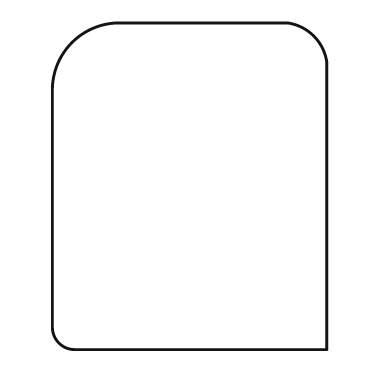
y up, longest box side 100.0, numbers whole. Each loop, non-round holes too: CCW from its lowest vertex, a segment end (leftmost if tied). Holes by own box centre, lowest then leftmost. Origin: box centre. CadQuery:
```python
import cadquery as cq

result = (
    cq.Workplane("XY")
    .moveTo(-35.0, -50.0)
    .lineTo(42.0, -50.0)
    .lineTo(42.0, 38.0)
    .threePointArc((38.0, 46.0), (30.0, 50.0))
    .lineTo(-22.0, 50.0)
    .threePointArc((-36.0, 44.0), (-42.0, 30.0))
    .lineTo(-42.0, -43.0)
    .threePointArc((-40.0, -48.0), (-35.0, -50.0))
    .close()
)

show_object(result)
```